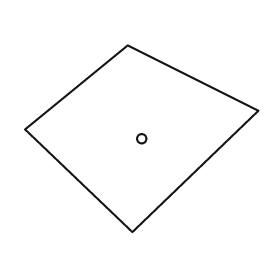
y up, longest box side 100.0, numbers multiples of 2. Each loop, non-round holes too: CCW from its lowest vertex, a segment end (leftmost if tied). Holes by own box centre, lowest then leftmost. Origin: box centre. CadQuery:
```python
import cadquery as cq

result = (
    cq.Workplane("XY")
    .moveTo(-4.0, -40.0)
    .lineTo(50.0, 12.0)
    .lineTo(-6.0, 40.0)
    .lineTo(-50.0, 4.0)
    .close()
    .moveTo(0.0, 0.0)
    .circle(2.0)
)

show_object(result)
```